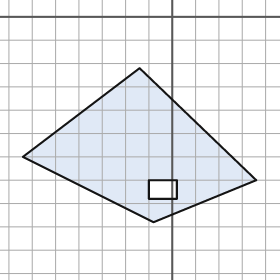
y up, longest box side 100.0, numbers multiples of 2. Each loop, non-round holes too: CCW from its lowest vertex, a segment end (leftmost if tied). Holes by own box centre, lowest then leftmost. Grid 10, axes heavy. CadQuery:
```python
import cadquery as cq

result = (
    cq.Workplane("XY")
    .moveTo(-8.0, -88.0)
    .lineTo(36.0, -70.0)
    .lineTo(-14.0, -22.0)
    .lineTo(-64.0, -60.0)
    .close()
    .moveTo(-10.0, -78.0)
    .lineTo(2.0, -78.0)
    .lineTo(2.0, -70.0)
    .lineTo(-10.0, -70.0)
    .close()
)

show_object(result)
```